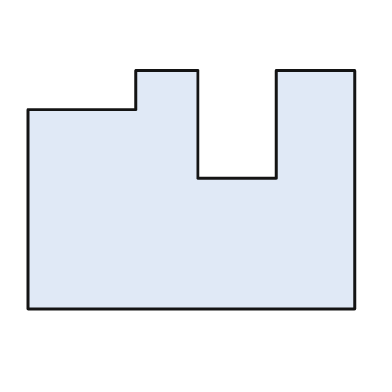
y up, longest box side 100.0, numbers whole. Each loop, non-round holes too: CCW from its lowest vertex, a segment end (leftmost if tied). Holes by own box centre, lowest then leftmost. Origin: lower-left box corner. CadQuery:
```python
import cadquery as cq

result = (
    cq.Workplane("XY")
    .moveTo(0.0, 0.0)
    .lineTo(100.0, 0.0)
    .lineTo(100.0, 73.0)
    .lineTo(76.0, 73.0)
    .lineTo(76.0, 40.0)
    .lineTo(52.0, 40.0)
    .lineTo(52.0, 73.0)
    .lineTo(33.0, 73.0)
    .lineTo(33.0, 61.0)
    .lineTo(0.0, 61.0)
    .close()
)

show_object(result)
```